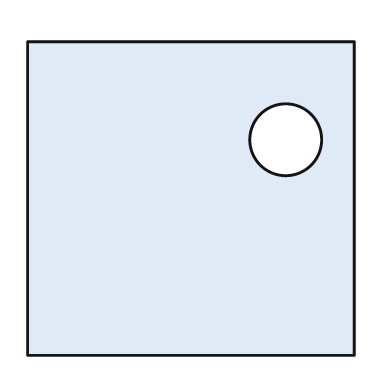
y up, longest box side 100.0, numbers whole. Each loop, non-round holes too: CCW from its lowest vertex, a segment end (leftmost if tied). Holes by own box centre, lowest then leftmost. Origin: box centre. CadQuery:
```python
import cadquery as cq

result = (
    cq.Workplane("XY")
    .moveTo(-50.0, -48.0)
    .lineTo(50.0, -48.0)
    .lineTo(50.0, 48.0)
    .lineTo(-50.0, 48.0)
    .close()
    .moveTo(29.0, 18.0)
    .circle(11.0)
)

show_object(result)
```